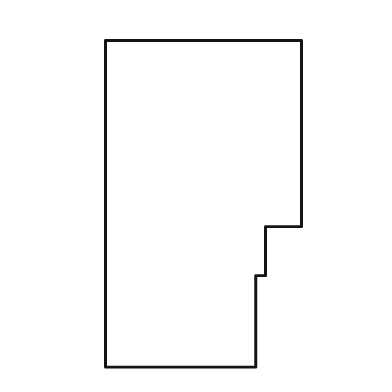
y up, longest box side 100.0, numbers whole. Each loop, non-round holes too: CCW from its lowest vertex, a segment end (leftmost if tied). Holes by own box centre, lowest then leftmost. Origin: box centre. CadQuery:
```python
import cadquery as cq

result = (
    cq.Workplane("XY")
    .moveTo(-30.0, -50.0)
    .lineTo(16.0, -50.0)
    .lineTo(16.0, -22.0)
    .lineTo(19.0, -22.0)
    .lineTo(19.0, -7.0)
    .lineTo(30.0, -7.0)
    .lineTo(30.0, 50.0)
    .lineTo(-30.0, 50.0)
    .close()
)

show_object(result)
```